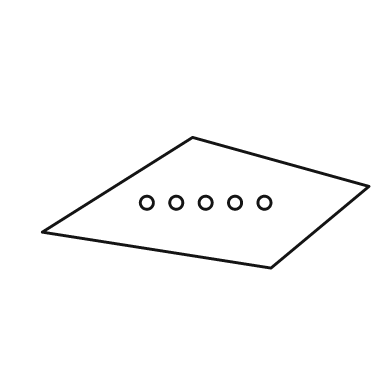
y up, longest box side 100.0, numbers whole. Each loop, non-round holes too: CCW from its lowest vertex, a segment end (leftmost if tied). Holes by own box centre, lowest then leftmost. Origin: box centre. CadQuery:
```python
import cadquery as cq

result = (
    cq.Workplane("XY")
    .moveTo(20.0, -20.0)
    .lineTo(50.0, 5.0)
    .lineTo(-4.0, 20.0)
    .lineTo(-50.0, -9.0)
    .close()
    .moveTo(-18.0, 0.0)
    .circle(2.0)
    .moveTo(-9.0, 0.0)
    .circle(2.0)
    .moveTo(0.0, 0.0)
    .circle(2.0)
    .moveTo(9.0, 0.0)
    .circle(2.0)
    .moveTo(18.0, 0.0)
    .circle(2.0)
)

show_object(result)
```